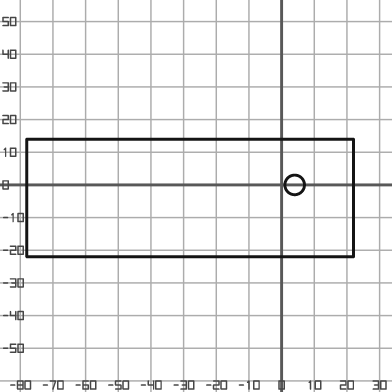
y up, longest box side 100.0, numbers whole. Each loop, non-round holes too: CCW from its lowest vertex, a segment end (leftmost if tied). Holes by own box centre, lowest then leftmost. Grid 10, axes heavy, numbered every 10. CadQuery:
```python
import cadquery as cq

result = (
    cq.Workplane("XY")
    .moveTo(-78.0, -22.0)
    .lineTo(22.0, -22.0)
    .lineTo(22.0, 14.0)
    .lineTo(-78.0, 14.0)
    .close()
    .moveTo(4.0, 0.0)
    .circle(3.0)
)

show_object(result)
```